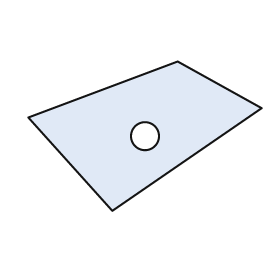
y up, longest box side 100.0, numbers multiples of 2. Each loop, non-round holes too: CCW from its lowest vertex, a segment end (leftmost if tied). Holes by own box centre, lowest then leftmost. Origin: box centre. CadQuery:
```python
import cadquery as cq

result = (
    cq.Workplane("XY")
    .moveTo(-14.0, -32.0)
    .lineTo(50.0, 12.0)
    .lineTo(14.0, 32.0)
    .lineTo(-50.0, 8.0)
    .close()
    .moveTo(0.0, 0.0)
    .circle(6.0)
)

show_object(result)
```